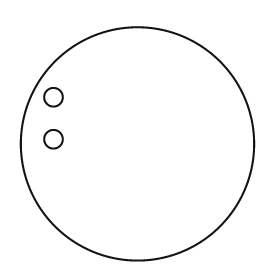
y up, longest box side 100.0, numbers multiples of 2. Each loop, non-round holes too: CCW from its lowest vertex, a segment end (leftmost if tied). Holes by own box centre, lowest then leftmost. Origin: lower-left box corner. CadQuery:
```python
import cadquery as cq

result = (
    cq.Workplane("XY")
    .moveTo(50.0, 50.0)
    .circle(50.0)
    .moveTo(14.0, 52.0)
    .circle(4.0)
    .moveTo(14.0, 70.0)
    .circle(4.0)
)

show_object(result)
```